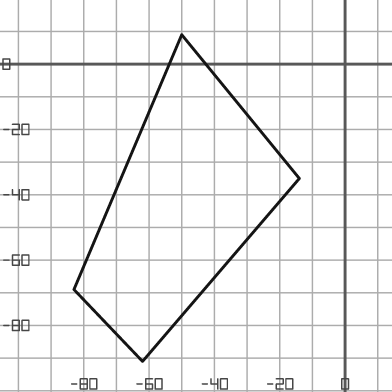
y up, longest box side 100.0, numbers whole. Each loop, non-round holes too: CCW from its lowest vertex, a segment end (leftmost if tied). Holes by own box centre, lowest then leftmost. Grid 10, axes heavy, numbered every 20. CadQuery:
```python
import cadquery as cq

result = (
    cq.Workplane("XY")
    .moveTo(-62.0, -91.0)
    .lineTo(-14.0, -35.0)
    .lineTo(-50.0, 9.0)
    .lineTo(-83.0, -69.0)
    .close()
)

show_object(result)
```